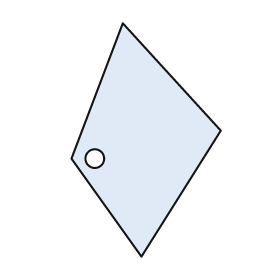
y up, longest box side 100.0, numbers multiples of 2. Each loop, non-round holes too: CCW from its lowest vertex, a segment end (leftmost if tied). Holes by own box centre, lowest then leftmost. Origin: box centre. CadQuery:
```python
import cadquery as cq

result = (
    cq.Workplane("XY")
    .moveTo(-2.0, -50.0)
    .lineTo(32.0, 4.0)
    .lineTo(-10.0, 50.0)
    .lineTo(-32.0, -8.0)
    .close()
    .moveTo(-22.0, -8.0)
    .circle(4.0)
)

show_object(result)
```